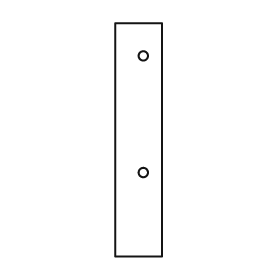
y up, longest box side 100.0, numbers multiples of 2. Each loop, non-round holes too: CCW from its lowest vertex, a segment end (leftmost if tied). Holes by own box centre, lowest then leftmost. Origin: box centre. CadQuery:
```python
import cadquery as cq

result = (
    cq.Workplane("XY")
    .moveTo(-10.0, -50.0)
    .lineTo(10.0, -50.0)
    .lineTo(10.0, 50.0)
    .lineTo(-10.0, 50.0)
    .close()
    .moveTo(2.0, -14.0)
    .circle(2.0)
    .moveTo(2.0, 36.0)
    .circle(2.0)
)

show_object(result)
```